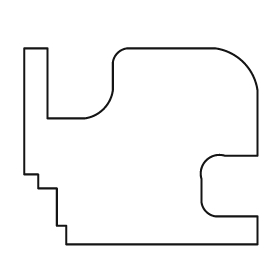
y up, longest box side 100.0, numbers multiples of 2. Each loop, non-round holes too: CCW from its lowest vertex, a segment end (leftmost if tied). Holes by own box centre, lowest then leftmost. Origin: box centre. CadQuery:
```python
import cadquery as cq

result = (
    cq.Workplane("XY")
    .moveTo(-32.0, -42.0)
    .lineTo(50.0, -42.0)
    .lineTo(50.0, -30.0)
    .lineTo(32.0, -30.0)
    .threePointArc((28.0, -28.0), (26.0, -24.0))
    .lineTo(26.0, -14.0)
    .threePointArc((28.0, -6.0), (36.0, -4.0))
    .lineTo(50.0, -4.0)
    .lineTo(50.0, 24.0)
    .threePointArc((44.0, 36.0), (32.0, 42.0))
    .lineTo(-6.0, 42.0)
    .threePointArc((-10.0, 40.0), (-12.0, 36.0))
    .lineTo(-12.0, 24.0)
    .threePointArc((-16.0, 16.0), (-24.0, 12.0))
    .lineTo(-40.0, 12.0)
    .lineTo(-40.0, 42.0)
    .lineTo(-50.0, 42.0)
    .lineTo(-50.0, -12.0)
    .lineTo(-44.0, -12.0)
    .lineTo(-44.0, -18.0)
    .lineTo(-36.0, -18.0)
    .lineTo(-36.0, -34.0)
    .lineTo(-32.0, -34.0)
    .close()
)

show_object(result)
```